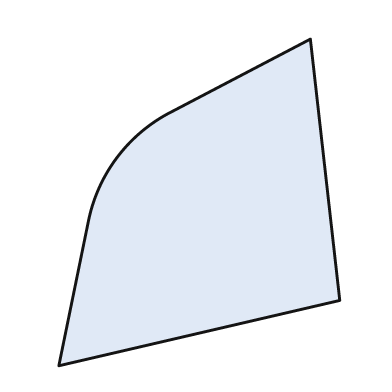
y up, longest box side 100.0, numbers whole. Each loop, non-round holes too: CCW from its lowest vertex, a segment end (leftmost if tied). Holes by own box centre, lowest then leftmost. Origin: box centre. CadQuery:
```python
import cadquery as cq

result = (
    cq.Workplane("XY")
    .moveTo(-43.0, -50.0)
    .lineTo(43.0, -30.0)
    .lineTo(34.0, 50.0)
    .lineTo(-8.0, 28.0)
    .threePointArc((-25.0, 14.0), (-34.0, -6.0))
    .close()
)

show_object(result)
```